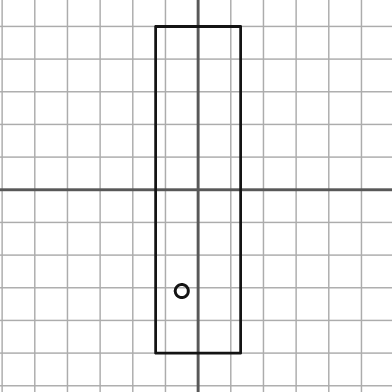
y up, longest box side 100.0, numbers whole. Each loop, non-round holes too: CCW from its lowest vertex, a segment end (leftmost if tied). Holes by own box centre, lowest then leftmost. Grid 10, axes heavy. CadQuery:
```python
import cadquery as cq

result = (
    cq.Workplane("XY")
    .moveTo(-13.0, -50.0)
    .lineTo(13.0, -50.0)
    .lineTo(13.0, 50.0)
    .lineTo(-13.0, 50.0)
    .close()
    .moveTo(-5.0, -31.0)
    .circle(2.0)
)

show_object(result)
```